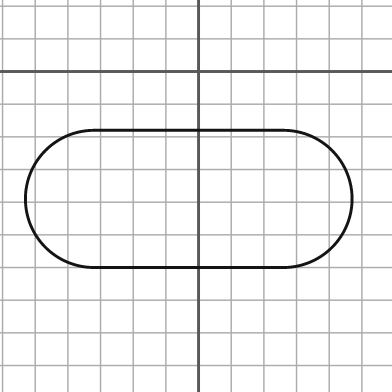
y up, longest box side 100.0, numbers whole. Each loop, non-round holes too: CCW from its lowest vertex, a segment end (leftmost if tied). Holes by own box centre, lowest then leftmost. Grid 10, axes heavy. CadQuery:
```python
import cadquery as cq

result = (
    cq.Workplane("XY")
    .moveTo(-32.0, -60.0)
    .lineTo(26.0, -60.0)
    .threePointArc((47.0, -39.0), (26.0, -18.0))
    .lineTo(-32.0, -18.0)
    .threePointArc((-53.0, -39.0), (-32.0, -60.0))
    .close()
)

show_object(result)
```